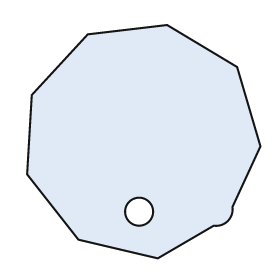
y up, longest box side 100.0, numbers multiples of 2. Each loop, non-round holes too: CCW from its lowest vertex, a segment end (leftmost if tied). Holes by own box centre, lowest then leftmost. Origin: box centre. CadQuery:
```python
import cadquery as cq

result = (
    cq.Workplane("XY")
    .moveTo(6.0, -50.0)
    .lineTo(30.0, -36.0)
    .threePointArc((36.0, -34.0), (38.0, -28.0))
    .lineTo(50.0, -2.0)
    .lineTo(40.0, 32.0)
    .lineTo(10.0, 50.0)
    .lineTo(-24.0, 46.0)
    .lineTo(-48.0, 20.0)
    .lineTo(-50.0, -14.0)
    .lineTo(-28.0, -42.0)
    .close()
    .moveTo(-2.0, -30.0)
    .circle(6.0)
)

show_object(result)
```